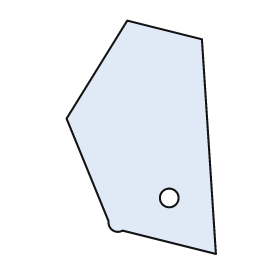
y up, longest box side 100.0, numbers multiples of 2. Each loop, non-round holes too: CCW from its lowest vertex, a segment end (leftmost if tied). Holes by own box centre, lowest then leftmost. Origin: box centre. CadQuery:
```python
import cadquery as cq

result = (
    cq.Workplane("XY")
    .moveTo(32.0, -50.0)
    .lineTo(26.0, 42.0)
    .lineTo(-6.0, 50.0)
    .lineTo(-32.0, 8.0)
    .lineTo(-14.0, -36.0)
    .threePointArc((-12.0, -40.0), (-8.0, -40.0))
    .close()
    .moveTo(12.0, -26.0)
    .circle(4.0)
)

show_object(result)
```